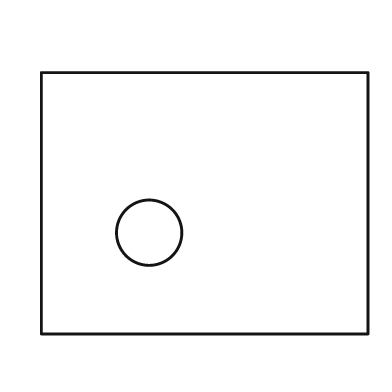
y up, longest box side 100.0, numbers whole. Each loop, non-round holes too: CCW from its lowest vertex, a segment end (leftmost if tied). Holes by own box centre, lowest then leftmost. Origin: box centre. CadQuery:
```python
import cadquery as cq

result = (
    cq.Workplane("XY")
    .moveTo(-50.0, -40.0)
    .lineTo(50.0, -40.0)
    .lineTo(50.0, 40.0)
    .lineTo(-50.0, 40.0)
    .close()
    .moveTo(-17.0, -9.0)
    .circle(10.0)
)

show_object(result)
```